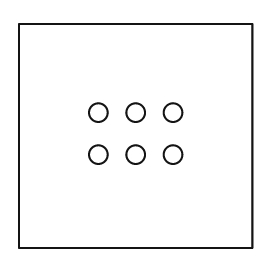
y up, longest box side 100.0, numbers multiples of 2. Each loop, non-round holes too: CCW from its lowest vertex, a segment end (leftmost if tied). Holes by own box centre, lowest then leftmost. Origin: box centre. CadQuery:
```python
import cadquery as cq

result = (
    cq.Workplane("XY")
    .moveTo(-50.0, -48.0)
    .lineTo(50.0, -48.0)
    .lineTo(50.0, 48.0)
    .lineTo(-50.0, 48.0)
    .close()
    .moveTo(-16.0, -8.0)
    .circle(4.0)
    .moveTo(0.0, -8.0)
    .circle(4.0)
    .moveTo(16.0, -8.0)
    .circle(4.0)
    .moveTo(-16.0, 10.0)
    .circle(4.0)
    .moveTo(0.0, 10.0)
    .circle(4.0)
    .moveTo(16.0, 10.0)
    .circle(4.0)
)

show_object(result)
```